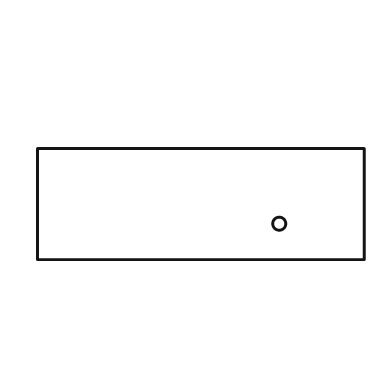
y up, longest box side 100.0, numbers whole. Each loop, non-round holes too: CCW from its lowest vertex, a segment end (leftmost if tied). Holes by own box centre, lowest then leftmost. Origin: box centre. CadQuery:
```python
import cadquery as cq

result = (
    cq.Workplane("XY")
    .moveTo(-50.0, -17.0)
    .lineTo(50.0, -17.0)
    .lineTo(50.0, 17.0)
    .lineTo(-50.0, 17.0)
    .close()
    .moveTo(24.0, -6.0)
    .circle(2.0)
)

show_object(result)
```